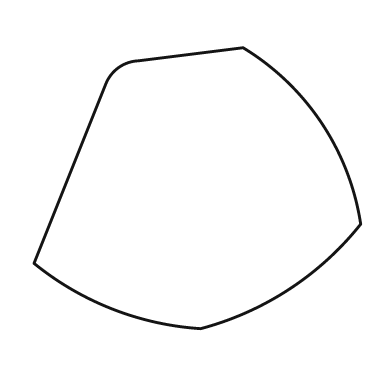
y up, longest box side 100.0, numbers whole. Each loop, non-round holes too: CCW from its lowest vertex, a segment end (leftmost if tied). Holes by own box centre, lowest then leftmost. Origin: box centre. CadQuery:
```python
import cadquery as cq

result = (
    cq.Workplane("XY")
    .moveTo(1.0, -43.0)
    .threePointArc((28.0, -31.0), (50.0, -11.0))
    .threePointArc((38.0, 20.0), (14.0, 43.0))
    .lineTo(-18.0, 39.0)
    .threePointArc((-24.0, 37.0), (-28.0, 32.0))
    .lineTo(-50.0, -23.0)
    .threePointArc((-26.0, -37.0), (1.0, -43.0))
    .close()
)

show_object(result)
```